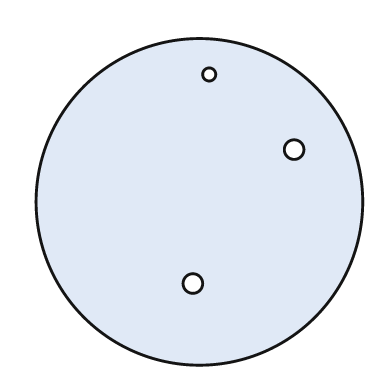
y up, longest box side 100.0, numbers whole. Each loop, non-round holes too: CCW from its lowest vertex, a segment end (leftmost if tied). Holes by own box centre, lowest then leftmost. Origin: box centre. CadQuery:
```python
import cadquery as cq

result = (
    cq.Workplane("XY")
    .moveTo(0.0, 0.0)
    .circle(50.0)
    .moveTo(-2.0, -25.0)
    .circle(3.0)
    .moveTo(29.0, 16.0)
    .circle(3.0)
    .moveTo(3.0, 39.0)
    .circle(2.0)
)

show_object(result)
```